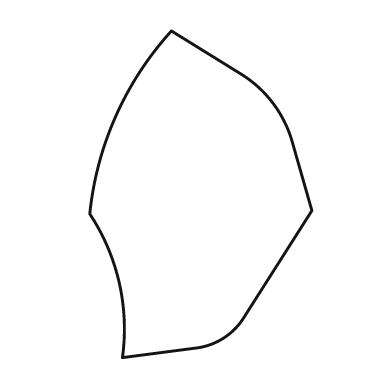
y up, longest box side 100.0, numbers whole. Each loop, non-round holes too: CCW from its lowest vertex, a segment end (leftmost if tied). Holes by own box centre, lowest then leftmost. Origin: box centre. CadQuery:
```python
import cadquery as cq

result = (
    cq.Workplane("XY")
    .moveTo(-24.0, -50.0)
    .lineTo(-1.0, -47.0)
    .threePointArc((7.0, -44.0), (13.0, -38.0))
    .lineTo(34.0, -5.0)
    .lineTo(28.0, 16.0)
    .threePointArc((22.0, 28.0), (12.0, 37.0))
    .lineTo(-9.0, 50.0)
    .threePointArc((-26.0, 24.0), (-34.0, -6.0))
    .threePointArc((-25.0, -27.0), (-24.0, -50.0))
    .close()
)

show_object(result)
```